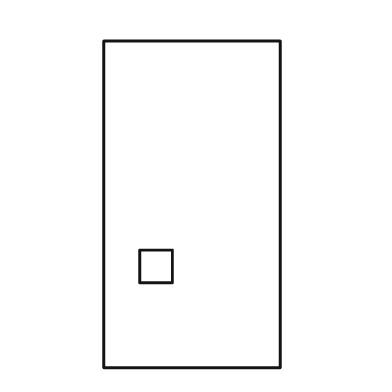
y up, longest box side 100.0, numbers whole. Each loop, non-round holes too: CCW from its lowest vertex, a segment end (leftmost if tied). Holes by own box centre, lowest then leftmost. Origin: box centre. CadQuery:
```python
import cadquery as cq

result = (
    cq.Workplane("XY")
    .moveTo(-27.0, -50.0)
    .lineTo(27.0, -50.0)
    .lineTo(27.0, 50.0)
    .lineTo(-27.0, 50.0)
    .close()
    .moveTo(-16.0, -24.0)
    .lineTo(-6.0, -24.0)
    .lineTo(-6.0, -14.0)
    .lineTo(-16.0, -14.0)
    .close()
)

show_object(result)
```